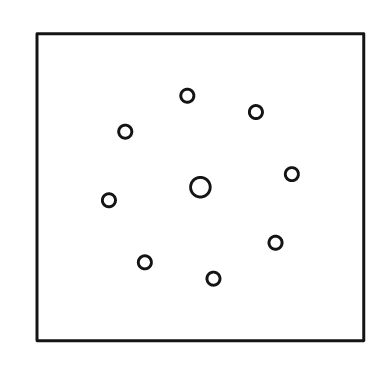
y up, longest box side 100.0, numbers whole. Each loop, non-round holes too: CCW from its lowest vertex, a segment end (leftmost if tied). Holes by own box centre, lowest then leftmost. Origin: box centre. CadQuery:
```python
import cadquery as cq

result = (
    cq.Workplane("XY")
    .moveTo(-50.0, -47.0)
    .lineTo(50.0, -47.0)
    .lineTo(50.0, 47.0)
    .lineTo(-50.0, 47.0)
    .close()
    .moveTo(4.0, -28.0)
    .circle(2.0)
    .moveTo(-17.0, -23.0)
    .circle(2.0)
    .moveTo(23.0, -17.0)
    .circle(2.0)
    .moveTo(-28.0, -4.0)
    .circle(2.0)
    .moveTo(0.0, 0.0)
    .circle(3.0)
    .moveTo(28.0, 4.0)
    .circle(2.0)
    .moveTo(-23.0, 17.0)
    .circle(2.0)
    .moveTo(17.0, 23.0)
    .circle(2.0)
    .moveTo(-4.0, 28.0)
    .circle(2.0)
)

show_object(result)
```